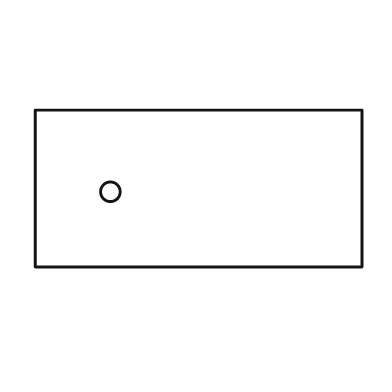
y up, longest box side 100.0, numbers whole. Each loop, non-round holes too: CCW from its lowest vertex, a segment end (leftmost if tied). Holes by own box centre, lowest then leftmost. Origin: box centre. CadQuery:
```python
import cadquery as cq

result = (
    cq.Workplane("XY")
    .moveTo(-50.0, -24.0)
    .lineTo(50.0, -24.0)
    .lineTo(50.0, 24.0)
    .lineTo(-50.0, 24.0)
    .close()
    .moveTo(-27.0, -1.0)
    .circle(3.0)
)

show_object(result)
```